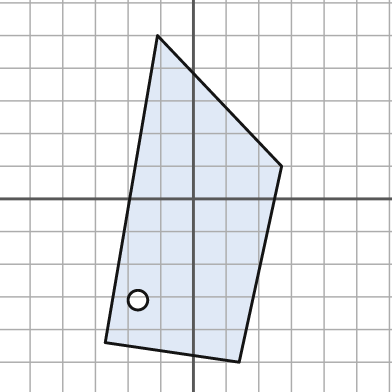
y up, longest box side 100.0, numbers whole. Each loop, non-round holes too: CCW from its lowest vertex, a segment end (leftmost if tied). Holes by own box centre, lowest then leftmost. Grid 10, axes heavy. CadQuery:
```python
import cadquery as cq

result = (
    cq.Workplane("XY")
    .moveTo(14.0, -50.0)
    .lineTo(27.0, 10.0)
    .lineTo(-11.0, 50.0)
    .lineTo(-27.0, -44.0)
    .close()
    .moveTo(-17.0, -31.0)
    .circle(3.0)
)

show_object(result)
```